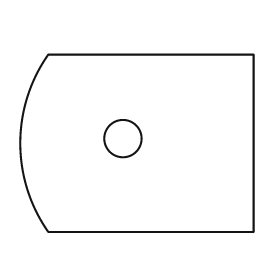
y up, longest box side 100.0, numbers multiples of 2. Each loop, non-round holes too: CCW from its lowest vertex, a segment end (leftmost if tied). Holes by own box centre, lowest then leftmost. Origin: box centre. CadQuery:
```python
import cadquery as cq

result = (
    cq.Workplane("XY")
    .moveTo(-38.0, -38.0)
    .lineTo(50.0, -38.0)
    .lineTo(50.0, 38.0)
    .lineTo(-38.0, 38.0)
    .threePointArc((-50.0, 0.0), (-38.0, -38.0))
    .close()
    .moveTo(-6.0, 2.0)
    .circle(8.0)
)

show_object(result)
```